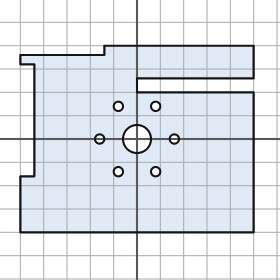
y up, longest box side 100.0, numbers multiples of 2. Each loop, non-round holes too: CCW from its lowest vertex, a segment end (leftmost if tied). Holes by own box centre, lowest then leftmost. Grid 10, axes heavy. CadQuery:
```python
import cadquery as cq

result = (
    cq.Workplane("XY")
    .moveTo(-50.0, -40.0)
    .lineTo(50.0, -40.0)
    .lineTo(50.0, 20.0)
    .lineTo(0.0, 20.0)
    .lineTo(0.0, 26.0)
    .lineTo(50.0, 26.0)
    .lineTo(50.0, 40.0)
    .lineTo(-14.0, 40.0)
    .lineTo(-14.0, 36.0)
    .lineTo(-50.0, 36.0)
    .lineTo(-50.0, 32.0)
    .lineTo(-44.0, 32.0)
    .lineTo(-44.0, -16.0)
    .lineTo(-50.0, -16.0)
    .close()
    .moveTo(-8.0, -14.0)
    .circle(2.0)
    .moveTo(8.0, -14.0)
    .circle(2.0)
    .moveTo(-16.0, 0.0)
    .circle(2.0)
    .moveTo(0.0, 0.0)
    .circle(6.0)
    .moveTo(16.0, 0.0)
    .circle(2.0)
    .moveTo(-8.0, 14.0)
    .circle(2.0)
    .moveTo(8.0, 14.0)
    .circle(2.0)
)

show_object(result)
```